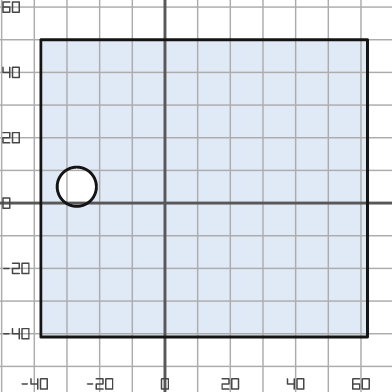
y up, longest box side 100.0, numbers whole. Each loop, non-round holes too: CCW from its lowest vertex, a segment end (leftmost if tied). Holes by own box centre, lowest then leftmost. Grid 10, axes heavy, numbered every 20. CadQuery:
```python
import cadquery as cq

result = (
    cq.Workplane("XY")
    .moveTo(-38.0, -41.0)
    .lineTo(62.0, -41.0)
    .lineTo(62.0, 50.0)
    .lineTo(-38.0, 50.0)
    .close()
    .moveTo(-27.0, 5.0)
    .circle(6.0)
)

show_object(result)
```